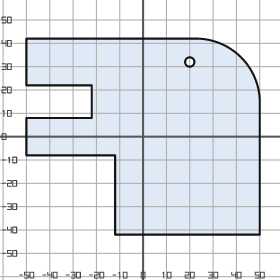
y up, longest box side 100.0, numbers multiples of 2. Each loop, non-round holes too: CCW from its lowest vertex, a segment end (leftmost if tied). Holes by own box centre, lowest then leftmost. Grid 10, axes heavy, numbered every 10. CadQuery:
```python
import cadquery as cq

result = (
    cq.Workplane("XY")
    .moveTo(-12.0, -42.0)
    .lineTo(50.0, -42.0)
    .lineTo(50.0, 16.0)
    .threePointArc((42.0, 34.0), (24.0, 42.0))
    .lineTo(-50.0, 42.0)
    .lineTo(-50.0, 22.0)
    .lineTo(-22.0, 22.0)
    .lineTo(-22.0, 8.0)
    .lineTo(-50.0, 8.0)
    .lineTo(-50.0, -8.0)
    .lineTo(-12.0, -8.0)
    .close()
    .moveTo(20.0, 32.0)
    .circle(2.0)
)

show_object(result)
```